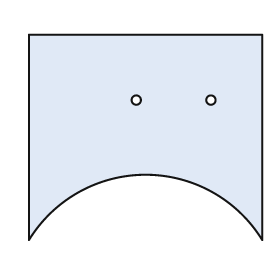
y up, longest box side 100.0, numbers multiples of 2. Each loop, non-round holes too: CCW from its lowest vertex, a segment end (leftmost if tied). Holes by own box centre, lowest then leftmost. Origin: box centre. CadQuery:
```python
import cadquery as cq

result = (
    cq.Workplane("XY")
    .moveTo(-50.0, -44.0)
    .threePointArc((0.0, -16.0), (50.0, -44.0))
    .lineTo(50.0, 44.0)
    .lineTo(-50.0, 44.0)
    .close()
    .moveTo(-4.0, 16.0)
    .circle(2.0)
    .moveTo(28.0, 16.0)
    .circle(2.0)
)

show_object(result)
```